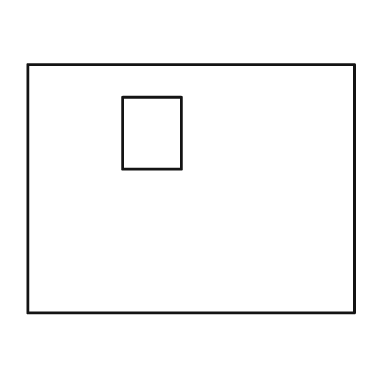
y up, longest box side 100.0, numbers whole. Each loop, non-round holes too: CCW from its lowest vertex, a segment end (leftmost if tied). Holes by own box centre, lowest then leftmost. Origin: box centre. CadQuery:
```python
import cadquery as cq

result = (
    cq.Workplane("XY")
    .moveTo(-50.0, -38.0)
    .lineTo(50.0, -38.0)
    .lineTo(50.0, 38.0)
    .lineTo(-50.0, 38.0)
    .close()
    .moveTo(-21.0, 6.0)
    .lineTo(-3.0, 6.0)
    .lineTo(-3.0, 28.0)
    .lineTo(-21.0, 28.0)
    .close()
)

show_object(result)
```